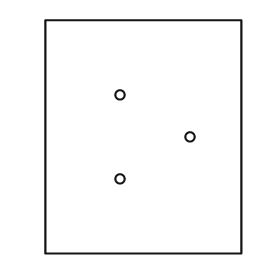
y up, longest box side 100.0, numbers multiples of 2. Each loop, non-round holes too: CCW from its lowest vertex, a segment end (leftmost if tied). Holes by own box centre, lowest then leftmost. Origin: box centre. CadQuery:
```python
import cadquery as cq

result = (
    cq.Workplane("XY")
    .moveTo(-42.0, -50.0)
    .lineTo(42.0, -50.0)
    .lineTo(42.0, 50.0)
    .lineTo(-42.0, 50.0)
    .close()
    .moveTo(-10.0, -18.0)
    .circle(2.0)
    .moveTo(20.0, 0.0)
    .circle(2.0)
    .moveTo(-10.0, 18.0)
    .circle(2.0)
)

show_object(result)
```